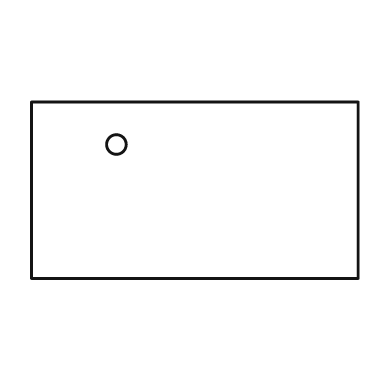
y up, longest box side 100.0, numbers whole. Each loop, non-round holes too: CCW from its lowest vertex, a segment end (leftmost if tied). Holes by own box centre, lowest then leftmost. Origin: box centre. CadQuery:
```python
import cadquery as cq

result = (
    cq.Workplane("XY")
    .moveTo(-50.0, -27.0)
    .lineTo(50.0, -27.0)
    .lineTo(50.0, 27.0)
    .lineTo(-50.0, 27.0)
    .close()
    .moveTo(-24.0, 14.0)
    .circle(3.0)
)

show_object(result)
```